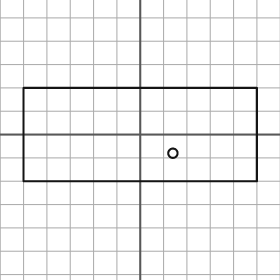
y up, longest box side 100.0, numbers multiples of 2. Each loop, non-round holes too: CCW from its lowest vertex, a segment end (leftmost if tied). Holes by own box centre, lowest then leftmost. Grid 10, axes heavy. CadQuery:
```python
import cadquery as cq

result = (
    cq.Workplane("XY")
    .moveTo(-50.0, -20.0)
    .lineTo(50.0, -20.0)
    .lineTo(50.0, 20.0)
    .lineTo(-50.0, 20.0)
    .close()
    .moveTo(14.0, -8.0)
    .circle(2.0)
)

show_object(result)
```